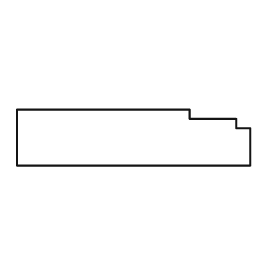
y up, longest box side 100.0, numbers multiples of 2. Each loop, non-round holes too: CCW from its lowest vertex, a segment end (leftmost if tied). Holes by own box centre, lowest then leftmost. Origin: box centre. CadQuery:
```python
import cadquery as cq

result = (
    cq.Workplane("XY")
    .moveTo(-50.0, -12.0)
    .lineTo(50.0, -12.0)
    .lineTo(50.0, 4.0)
    .lineTo(44.0, 4.0)
    .lineTo(44.0, 8.0)
    .lineTo(24.0, 8.0)
    .lineTo(24.0, 12.0)
    .lineTo(-50.0, 12.0)
    .close()
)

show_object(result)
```